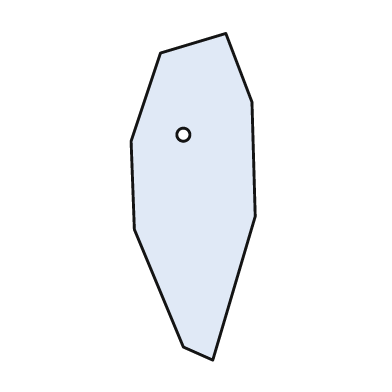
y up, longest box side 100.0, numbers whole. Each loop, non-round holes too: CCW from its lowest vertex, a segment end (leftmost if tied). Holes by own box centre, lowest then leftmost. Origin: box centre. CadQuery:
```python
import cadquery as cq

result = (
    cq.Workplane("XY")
    .moveTo(6.0, -50.0)
    .lineTo(19.0, -6.0)
    .lineTo(18.0, 29.0)
    .lineTo(10.0, 50.0)
    .lineTo(-10.0, 44.0)
    .lineTo(-19.0, 17.0)
    .lineTo(-18.0, -10.0)
    .lineTo(-3.0, -46.0)
    .close()
    .moveTo(-3.0, 19.0)
    .circle(2.0)
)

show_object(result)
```